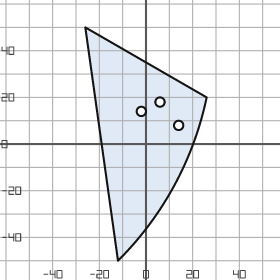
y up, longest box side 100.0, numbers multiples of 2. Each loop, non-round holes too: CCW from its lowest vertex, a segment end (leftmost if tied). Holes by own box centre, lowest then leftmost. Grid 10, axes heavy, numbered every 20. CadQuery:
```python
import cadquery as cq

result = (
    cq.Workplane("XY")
    .moveTo(-12.0, -50.0)
    .threePointArc((12.0, -18.0), (26.0, 20.0))
    .lineTo(-26.0, 50.0)
    .close()
    .moveTo(14.0, 8.0)
    .circle(2.0)
    .moveTo(-2.0, 14.0)
    .circle(2.0)
    .moveTo(6.0, 18.0)
    .circle(2.0)
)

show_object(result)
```